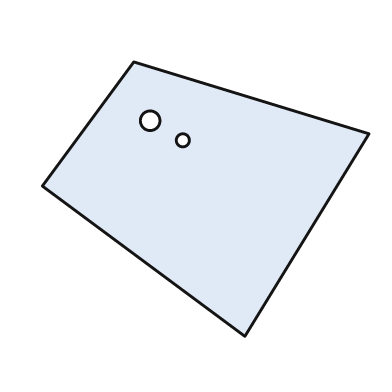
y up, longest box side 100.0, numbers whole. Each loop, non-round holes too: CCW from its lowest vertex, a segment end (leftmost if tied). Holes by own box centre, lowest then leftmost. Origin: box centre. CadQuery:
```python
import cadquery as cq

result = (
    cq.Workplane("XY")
    .moveTo(12.0, -42.0)
    .lineTo(50.0, 20.0)
    .lineTo(-22.0, 42.0)
    .lineTo(-50.0, 4.0)
    .close()
    .moveTo(-7.0, 18.0)
    .circle(2.0)
    .moveTo(-17.0, 24.0)
    .circle(3.0)
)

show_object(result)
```